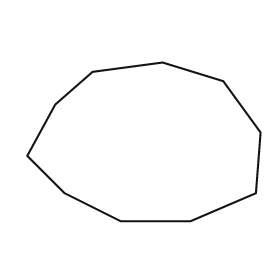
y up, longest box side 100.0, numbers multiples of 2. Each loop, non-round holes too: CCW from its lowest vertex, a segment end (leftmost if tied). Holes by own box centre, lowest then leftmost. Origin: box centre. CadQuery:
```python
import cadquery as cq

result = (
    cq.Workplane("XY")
    .moveTo(-10.0, -34.0)
    .lineTo(20.0, -34.0)
    .lineTo(48.0, -22.0)
    .lineTo(50.0, 4.0)
    .lineTo(34.0, 26.0)
    .lineTo(8.0, 34.0)
    .lineTo(-22.0, 30.0)
    .lineTo(-38.0, 16.0)
    .lineTo(-50.0, -6.0)
    .lineTo(-34.0, -22.0)
    .close()
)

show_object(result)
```